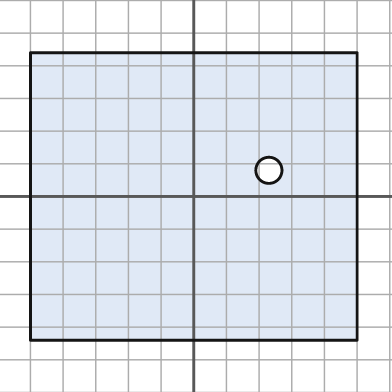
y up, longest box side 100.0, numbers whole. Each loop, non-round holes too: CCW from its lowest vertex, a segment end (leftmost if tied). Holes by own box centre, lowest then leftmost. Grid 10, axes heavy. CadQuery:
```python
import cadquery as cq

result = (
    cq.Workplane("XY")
    .moveTo(-50.0, -44.0)
    .lineTo(50.0, -44.0)
    .lineTo(50.0, 44.0)
    .lineTo(-50.0, 44.0)
    .close()
    .moveTo(23.0, 8.0)
    .circle(4.0)
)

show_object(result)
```